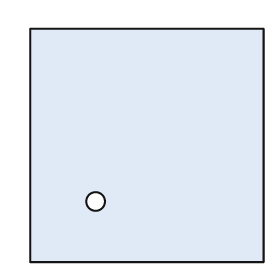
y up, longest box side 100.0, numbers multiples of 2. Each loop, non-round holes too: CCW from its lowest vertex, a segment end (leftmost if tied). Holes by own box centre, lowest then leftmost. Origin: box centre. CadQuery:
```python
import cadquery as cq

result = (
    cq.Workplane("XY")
    .moveTo(-50.0, -50.0)
    .lineTo(50.0, -50.0)
    .lineTo(50.0, 50.0)
    .lineTo(-50.0, 50.0)
    .close()
    .moveTo(-22.0, -24.0)
    .circle(4.0)
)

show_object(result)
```